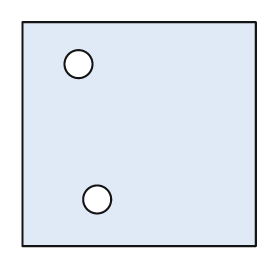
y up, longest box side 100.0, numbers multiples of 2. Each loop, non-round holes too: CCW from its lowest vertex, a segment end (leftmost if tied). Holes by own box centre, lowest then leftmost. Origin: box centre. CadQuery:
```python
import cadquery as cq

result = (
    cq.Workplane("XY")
    .moveTo(-50.0, -48.0)
    .lineTo(50.0, -48.0)
    .lineTo(50.0, 48.0)
    .lineTo(-50.0, 48.0)
    .close()
    .moveTo(-18.0, -28.0)
    .circle(6.0)
    .moveTo(-26.0, 30.0)
    .circle(6.0)
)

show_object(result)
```